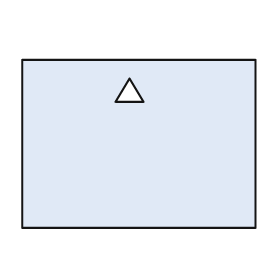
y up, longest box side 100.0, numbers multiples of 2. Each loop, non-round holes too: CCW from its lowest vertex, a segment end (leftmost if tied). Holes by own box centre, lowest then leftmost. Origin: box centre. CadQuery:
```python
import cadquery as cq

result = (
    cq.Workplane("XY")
    .moveTo(-50.0, -36.0)
    .lineTo(50.0, -36.0)
    .lineTo(50.0, 36.0)
    .lineTo(-50.0, 36.0)
    .close()
    .moveTo(-10.0, 18.0)
    .lineTo(2.0, 18.0)
    .lineTo(-4.0, 28.0)
    .close()
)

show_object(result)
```